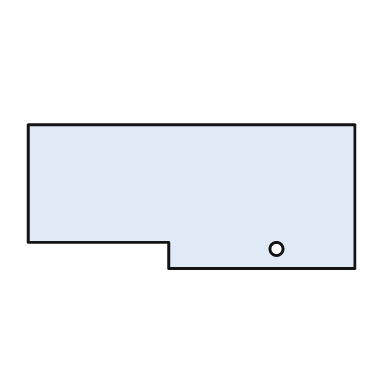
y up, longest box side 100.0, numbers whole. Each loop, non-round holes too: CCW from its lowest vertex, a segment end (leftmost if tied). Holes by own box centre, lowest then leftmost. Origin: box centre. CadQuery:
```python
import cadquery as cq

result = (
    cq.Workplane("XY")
    .moveTo(-7.0, -22.0)
    .lineTo(50.0, -22.0)
    .lineTo(50.0, 22.0)
    .lineTo(-50.0, 22.0)
    .lineTo(-50.0, -14.0)
    .lineTo(-7.0, -14.0)
    .close()
    .moveTo(26.0, -16.0)
    .circle(2.0)
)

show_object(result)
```